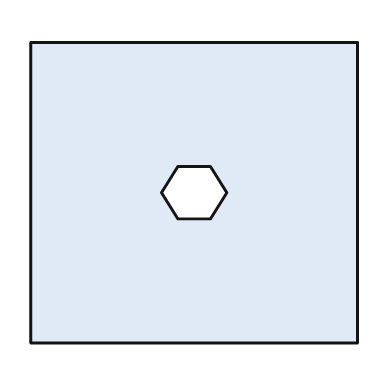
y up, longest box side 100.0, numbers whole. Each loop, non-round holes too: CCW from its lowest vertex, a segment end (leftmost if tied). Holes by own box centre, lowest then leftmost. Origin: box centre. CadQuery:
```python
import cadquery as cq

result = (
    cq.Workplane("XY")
    .moveTo(-50.0, -46.0)
    .lineTo(50.0, -46.0)
    .lineTo(50.0, 46.0)
    .lineTo(-50.0, 46.0)
    .close()
    .moveTo(-5.0, -8.0)
    .lineTo(5.0, -8.0)
    .lineTo(10.0, 0.0)
    .lineTo(5.0, 8.0)
    .lineTo(-5.0, 8.0)
    .lineTo(-10.0, 0.0)
    .close()
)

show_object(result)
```